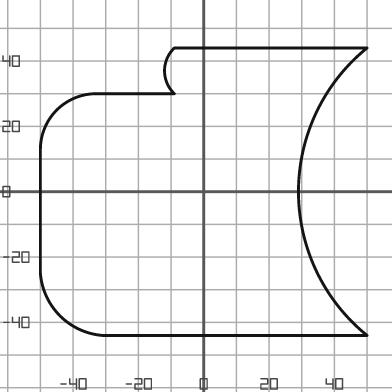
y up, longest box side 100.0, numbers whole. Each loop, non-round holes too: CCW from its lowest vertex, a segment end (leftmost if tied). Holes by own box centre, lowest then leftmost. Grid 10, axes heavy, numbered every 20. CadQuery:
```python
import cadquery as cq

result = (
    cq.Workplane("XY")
    .moveTo(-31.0, -44.0)
    .lineTo(50.0, -44.0)
    .threePointArc((29.0, 0.0), (50.0, 44.0))
    .lineTo(-9.0, 44.0)
    .threePointArc((-12.0, 37.0), (-9.0, 30.0))
    .lineTo(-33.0, 30.0)
    .threePointArc((-45.0, 25.0), (-50.0, 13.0))
    .lineTo(-50.0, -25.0)
    .threePointArc((-44.0, -38.0), (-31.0, -44.0))
    .close()
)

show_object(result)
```